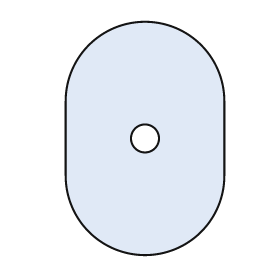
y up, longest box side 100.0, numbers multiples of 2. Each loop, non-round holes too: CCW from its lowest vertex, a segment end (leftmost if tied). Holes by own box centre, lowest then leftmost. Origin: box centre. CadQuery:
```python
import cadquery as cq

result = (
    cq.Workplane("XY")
    .moveTo(-34.0, -16.0)
    .threePointArc((0.0, -50.0), (34.0, -16.0))
    .lineTo(34.0, 16.0)
    .threePointArc((0.0, 50.0), (-34.0, 16.0))
    .close()
    .moveTo(0.0, 0.0)
    .circle(6.0)
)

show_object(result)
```